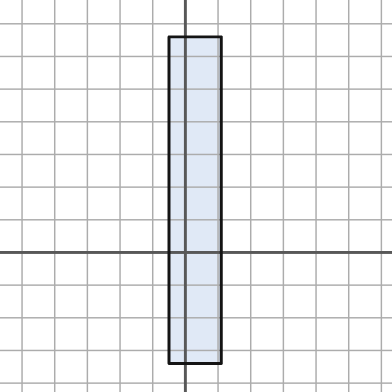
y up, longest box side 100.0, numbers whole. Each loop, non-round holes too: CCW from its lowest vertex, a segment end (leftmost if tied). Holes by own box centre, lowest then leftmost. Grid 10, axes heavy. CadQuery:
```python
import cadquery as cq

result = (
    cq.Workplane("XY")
    .moveTo(-5.0, -34.0)
    .lineTo(11.0, -34.0)
    .lineTo(11.0, 66.0)
    .lineTo(-5.0, 66.0)
    .close()
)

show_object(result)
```